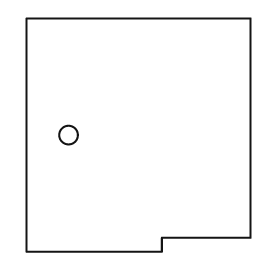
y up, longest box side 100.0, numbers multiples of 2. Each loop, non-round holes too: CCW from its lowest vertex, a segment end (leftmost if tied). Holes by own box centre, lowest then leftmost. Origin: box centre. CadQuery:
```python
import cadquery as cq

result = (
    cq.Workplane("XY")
    .moveTo(-48.0, -50.0)
    .lineTo(10.0, -50.0)
    .lineTo(10.0, -44.0)
    .lineTo(48.0, -44.0)
    .lineTo(48.0, 50.0)
    .lineTo(-48.0, 50.0)
    .close()
    .moveTo(-30.0, 0.0)
    .circle(4.0)
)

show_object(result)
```